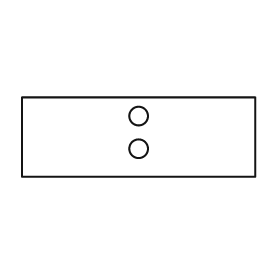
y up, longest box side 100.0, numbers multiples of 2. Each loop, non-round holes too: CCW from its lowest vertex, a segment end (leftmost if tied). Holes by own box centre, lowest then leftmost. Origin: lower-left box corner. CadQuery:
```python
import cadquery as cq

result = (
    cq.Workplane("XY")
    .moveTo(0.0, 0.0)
    .lineTo(100.0, 0.0)
    .lineTo(100.0, 34.0)
    .lineTo(0.0, 34.0)
    .close()
    .moveTo(50.0, 12.0)
    .circle(4.0)
    .moveTo(50.0, 26.0)
    .circle(4.0)
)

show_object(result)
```